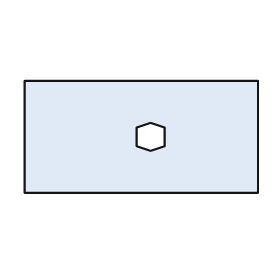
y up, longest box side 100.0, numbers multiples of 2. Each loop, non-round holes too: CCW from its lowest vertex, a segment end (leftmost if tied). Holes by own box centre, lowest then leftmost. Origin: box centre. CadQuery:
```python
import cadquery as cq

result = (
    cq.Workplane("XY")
    .moveTo(-50.0, -24.0)
    .lineTo(50.0, -24.0)
    .lineTo(50.0, 24.0)
    .lineTo(-50.0, 24.0)
    .close()
    .moveTo(4.0, -6.0)
    .lineTo(10.0, -4.0)
    .lineTo(10.0, 4.0)
    .lineTo(4.0, 6.0)
    .lineTo(-2.0, 4.0)
    .lineTo(-2.0, -4.0)
    .close()
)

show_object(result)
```